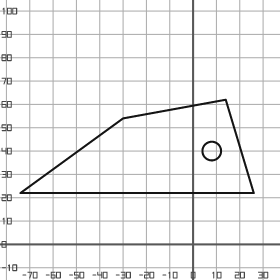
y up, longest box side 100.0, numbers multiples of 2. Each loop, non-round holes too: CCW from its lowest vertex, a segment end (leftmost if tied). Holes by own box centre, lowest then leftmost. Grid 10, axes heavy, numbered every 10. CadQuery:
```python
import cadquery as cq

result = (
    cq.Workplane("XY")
    .moveTo(-74.0, 22.0)
    .lineTo(26.0, 22.0)
    .lineTo(14.0, 62.0)
    .lineTo(-30.0, 54.0)
    .close()
    .moveTo(8.0, 40.0)
    .circle(4.0)
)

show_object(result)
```